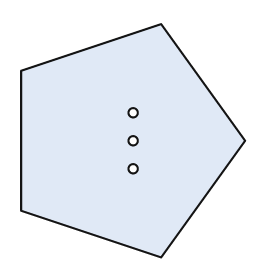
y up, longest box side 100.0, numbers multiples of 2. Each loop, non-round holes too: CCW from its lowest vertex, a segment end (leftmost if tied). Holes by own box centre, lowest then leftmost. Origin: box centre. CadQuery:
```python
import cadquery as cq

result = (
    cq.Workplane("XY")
    .moveTo(12.0, -50.0)
    .lineTo(48.0, 0.0)
    .lineTo(12.0, 50.0)
    .lineTo(-48.0, 30.0)
    .lineTo(-48.0, -30.0)
    .close()
    .moveTo(0.0, -12.0)
    .circle(2.0)
    .moveTo(0.0, 0.0)
    .circle(2.0)
    .moveTo(0.0, 12.0)
    .circle(2.0)
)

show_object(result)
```